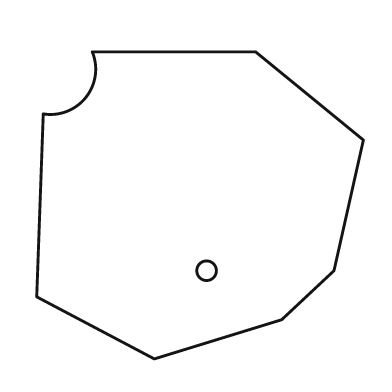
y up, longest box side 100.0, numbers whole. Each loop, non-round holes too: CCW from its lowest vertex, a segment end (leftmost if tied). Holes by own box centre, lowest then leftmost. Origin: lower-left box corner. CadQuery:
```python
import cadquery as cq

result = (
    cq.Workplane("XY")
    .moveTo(36.0, 0.0)
    .lineTo(75.0, 12.0)
    .lineTo(91.0, 27.0)
    .lineTo(100.0, 67.0)
    .lineTo(67.0, 94.0)
    .lineTo(17.0, 94.0)
    .threePointArc((15.0, 80.0), (2.0, 75.0))
    .lineTo(0.0, 19.0)
    .close()
    .moveTo(52.0, 27.0)
    .circle(3.0)
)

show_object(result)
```